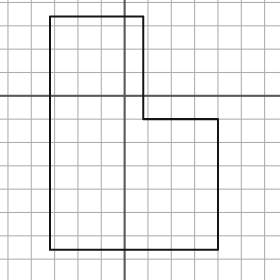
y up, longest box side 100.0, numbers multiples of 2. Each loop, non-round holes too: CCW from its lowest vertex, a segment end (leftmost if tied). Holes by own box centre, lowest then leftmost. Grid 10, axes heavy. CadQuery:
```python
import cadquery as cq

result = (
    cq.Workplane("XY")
    .moveTo(-32.0, -66.0)
    .lineTo(40.0, -66.0)
    .lineTo(40.0, -10.0)
    .lineTo(8.0, -10.0)
    .lineTo(8.0, 34.0)
    .lineTo(-32.0, 34.0)
    .close()
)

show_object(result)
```